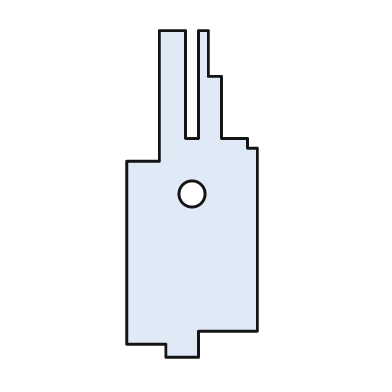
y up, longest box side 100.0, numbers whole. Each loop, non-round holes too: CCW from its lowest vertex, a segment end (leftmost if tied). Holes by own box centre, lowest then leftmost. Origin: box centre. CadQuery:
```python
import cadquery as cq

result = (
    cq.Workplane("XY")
    .moveTo(-8.0, -50.0)
    .lineTo(2.0, -50.0)
    .lineTo(2.0, -42.0)
    .lineTo(20.0, -42.0)
    .lineTo(20.0, 14.0)
    .lineTo(17.0, 14.0)
    .lineTo(17.0, 17.0)
    .lineTo(9.0, 17.0)
    .lineTo(9.0, 36.0)
    .lineTo(5.0, 36.0)
    .lineTo(5.0, 50.0)
    .lineTo(2.0, 50.0)
    .lineTo(2.0, 17.0)
    .lineTo(-2.0, 17.0)
    .lineTo(-2.0, 50.0)
    .lineTo(-10.0, 50.0)
    .lineTo(-10.0, 10.0)
    .lineTo(-20.0, 10.0)
    .lineTo(-20.0, -46.0)
    .lineTo(-8.0, -46.0)
    .close()
    .moveTo(0.0, 0.0)
    .circle(4.0)
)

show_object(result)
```